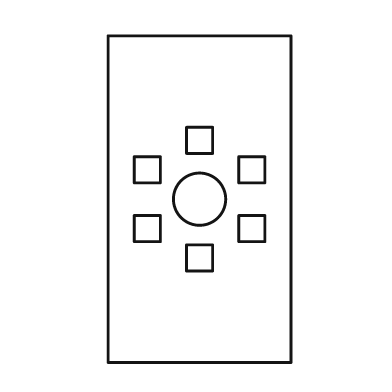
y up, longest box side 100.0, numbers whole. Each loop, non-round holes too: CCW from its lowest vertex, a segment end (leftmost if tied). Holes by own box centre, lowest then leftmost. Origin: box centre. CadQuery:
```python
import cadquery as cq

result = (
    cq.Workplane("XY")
    .moveTo(-28.0, -50.0)
    .lineTo(28.0, -50.0)
    .lineTo(28.0, 50.0)
    .lineTo(-28.0, 50.0)
    .close()
    .moveTo(-4.0, -22.0)
    .lineTo(4.0, -22.0)
    .lineTo(4.0, -14.0)
    .lineTo(-4.0, -14.0)
    .close()
    .moveTo(-20.0, -13.0)
    .lineTo(-12.0, -13.0)
    .lineTo(-12.0, -5.0)
    .lineTo(-20.0, -5.0)
    .close()
    .moveTo(12.0, -13.0)
    .lineTo(20.0, -13.0)
    .lineTo(20.0, -5.0)
    .lineTo(12.0, -5.0)
    .close()
    .moveTo(0.0, 0.0)
    .circle(8.0)
    .moveTo(-20.0, 5.0)
    .lineTo(-12.0, 5.0)
    .lineTo(-12.0, 13.0)
    .lineTo(-20.0, 13.0)
    .close()
    .moveTo(12.0, 5.0)
    .lineTo(20.0, 5.0)
    .lineTo(20.0, 13.0)
    .lineTo(12.0, 13.0)
    .close()
    .moveTo(-4.0, 14.0)
    .lineTo(4.0, 14.0)
    .lineTo(4.0, 22.0)
    .lineTo(-4.0, 22.0)
    .close()
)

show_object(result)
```